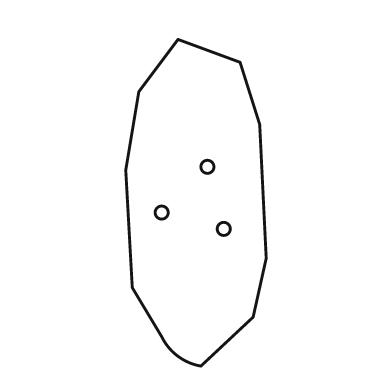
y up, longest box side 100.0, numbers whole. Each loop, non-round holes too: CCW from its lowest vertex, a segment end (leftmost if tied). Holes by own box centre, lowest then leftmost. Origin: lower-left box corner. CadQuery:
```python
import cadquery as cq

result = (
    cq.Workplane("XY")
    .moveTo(23.0, 0.0)
    .lineTo(39.0, 15.0)
    .lineTo(43.0, 33.0)
    .lineTo(41.0, 74.0)
    .lineTo(35.0, 93.0)
    .lineTo(16.0, 100.0)
    .lineTo(4.0, 84.0)
    .lineTo(0.0, 60.0)
    .lineTo(2.0, 24.0)
    .lineTo(11.0, 9.0)
    .threePointArc((16.0, 3.0), (23.0, 0.0))
    .close()
    .moveTo(30.0, 42.0)
    .circle(2.0)
    .moveTo(11.0, 47.0)
    .circle(2.0)
    .moveTo(25.0, 61.0)
    .circle(2.0)
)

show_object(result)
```